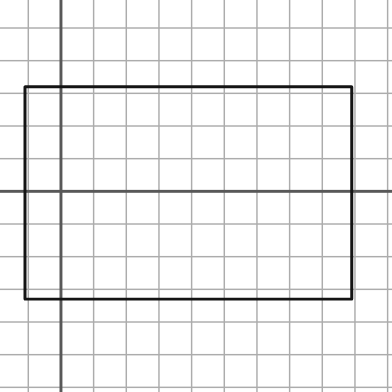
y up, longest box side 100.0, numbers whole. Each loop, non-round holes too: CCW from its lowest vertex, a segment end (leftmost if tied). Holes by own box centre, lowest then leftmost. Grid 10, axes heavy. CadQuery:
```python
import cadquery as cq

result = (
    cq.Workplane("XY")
    .moveTo(-11.0, -33.0)
    .lineTo(89.0, -33.0)
    .lineTo(89.0, 32.0)
    .lineTo(-11.0, 32.0)
    .close()
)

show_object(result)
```